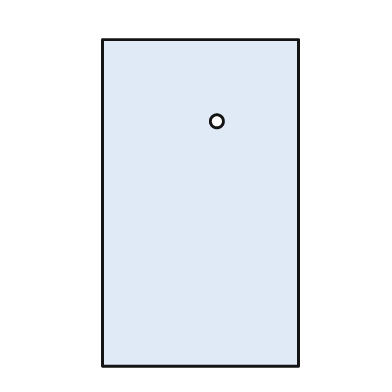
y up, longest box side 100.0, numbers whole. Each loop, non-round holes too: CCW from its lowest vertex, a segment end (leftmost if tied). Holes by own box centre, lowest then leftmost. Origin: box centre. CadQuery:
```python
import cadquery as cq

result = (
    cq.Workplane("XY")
    .moveTo(-30.0, -50.0)
    .lineTo(30.0, -50.0)
    .lineTo(30.0, 50.0)
    .lineTo(-30.0, 50.0)
    .close()
    .moveTo(5.0, 25.0)
    .circle(2.0)
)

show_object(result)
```